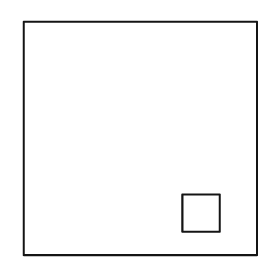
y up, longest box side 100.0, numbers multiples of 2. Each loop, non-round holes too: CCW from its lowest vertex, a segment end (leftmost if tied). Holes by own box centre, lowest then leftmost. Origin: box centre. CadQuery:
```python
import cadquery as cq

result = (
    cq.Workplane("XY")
    .moveTo(-50.0, -50.0)
    .lineTo(50.0, -50.0)
    .lineTo(50.0, 50.0)
    .lineTo(-50.0, 50.0)
    .close()
    .moveTo(18.0, -40.0)
    .lineTo(34.0, -40.0)
    .lineTo(34.0, -24.0)
    .lineTo(18.0, -24.0)
    .close()
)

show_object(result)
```